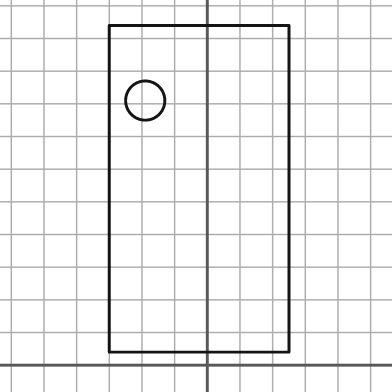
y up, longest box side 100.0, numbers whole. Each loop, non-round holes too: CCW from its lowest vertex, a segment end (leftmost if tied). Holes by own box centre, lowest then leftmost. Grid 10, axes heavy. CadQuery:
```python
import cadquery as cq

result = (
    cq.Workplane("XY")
    .moveTo(-30.0, 4.0)
    .lineTo(25.0, 4.0)
    .lineTo(25.0, 104.0)
    .lineTo(-30.0, 104.0)
    .close()
    .moveTo(-19.0, 81.0)
    .circle(6.0)
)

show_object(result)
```